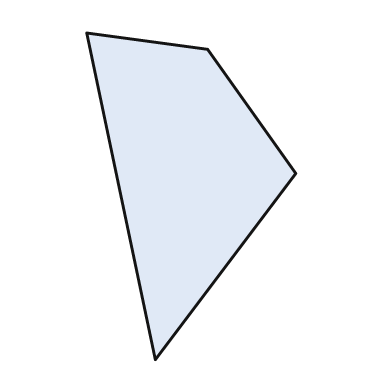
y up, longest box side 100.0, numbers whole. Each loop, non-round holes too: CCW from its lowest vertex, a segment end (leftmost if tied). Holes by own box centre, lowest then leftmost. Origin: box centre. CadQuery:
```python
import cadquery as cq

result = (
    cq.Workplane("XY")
    .moveTo(-11.0, -50.0)
    .lineTo(32.0, 7.0)
    .lineTo(5.0, 45.0)
    .lineTo(-32.0, 50.0)
    .close()
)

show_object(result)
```